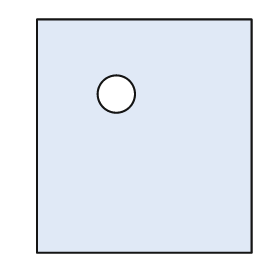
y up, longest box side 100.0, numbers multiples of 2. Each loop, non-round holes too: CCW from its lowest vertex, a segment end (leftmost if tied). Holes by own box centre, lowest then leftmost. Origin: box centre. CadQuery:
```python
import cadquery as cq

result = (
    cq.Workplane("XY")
    .moveTo(-46.0, -50.0)
    .lineTo(46.0, -50.0)
    .lineTo(46.0, 50.0)
    .lineTo(-46.0, 50.0)
    .close()
    .moveTo(-12.0, 18.0)
    .circle(8.0)
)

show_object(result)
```